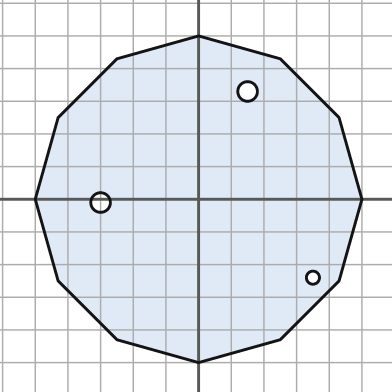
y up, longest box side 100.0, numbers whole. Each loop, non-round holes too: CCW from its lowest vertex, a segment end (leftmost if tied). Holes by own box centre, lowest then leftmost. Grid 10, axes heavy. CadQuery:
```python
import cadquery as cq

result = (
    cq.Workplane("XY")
    .moveTo(0.0, -50.0)
    .lineTo(25.0, -43.0)
    .lineTo(43.0, -25.0)
    .lineTo(50.0, 0.0)
    .lineTo(43.0, 25.0)
    .lineTo(25.0, 43.0)
    .lineTo(0.0, 50.0)
    .lineTo(-25.0, 43.0)
    .lineTo(-43.0, 25.0)
    .lineTo(-50.0, 0.0)
    .lineTo(-43.0, -25.0)
    .lineTo(-25.0, -43.0)
    .close()
    .moveTo(35.0, -24.0)
    .circle(2.0)
    .moveTo(-30.0, -1.0)
    .circle(3.0)
    .moveTo(15.0, 33.0)
    .circle(3.0)
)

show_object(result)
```